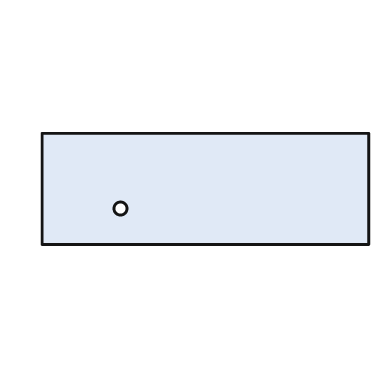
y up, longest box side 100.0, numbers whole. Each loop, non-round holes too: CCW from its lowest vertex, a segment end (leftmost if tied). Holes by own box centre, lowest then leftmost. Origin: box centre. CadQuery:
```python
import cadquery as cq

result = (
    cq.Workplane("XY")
    .moveTo(-50.0, -17.0)
    .lineTo(50.0, -17.0)
    .lineTo(50.0, 17.0)
    .lineTo(-50.0, 17.0)
    .close()
    .moveTo(-26.0, -6.0)
    .circle(2.0)
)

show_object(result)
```